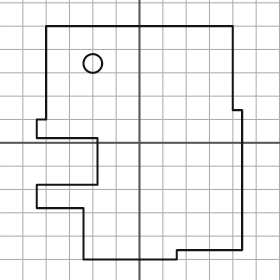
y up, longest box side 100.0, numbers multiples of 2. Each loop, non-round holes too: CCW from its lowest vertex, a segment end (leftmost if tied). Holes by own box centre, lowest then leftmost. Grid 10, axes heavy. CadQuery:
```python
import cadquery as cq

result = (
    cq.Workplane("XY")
    .moveTo(-24.0, -50.0)
    .lineTo(16.0, -50.0)
    .lineTo(16.0, -46.0)
    .lineTo(44.0, -46.0)
    .lineTo(44.0, 14.0)
    .lineTo(40.0, 14.0)
    .lineTo(40.0, 50.0)
    .lineTo(-40.0, 50.0)
    .lineTo(-40.0, 10.0)
    .lineTo(-44.0, 10.0)
    .lineTo(-44.0, 2.0)
    .lineTo(-18.0, 2.0)
    .lineTo(-18.0, -18.0)
    .lineTo(-44.0, -18.0)
    .lineTo(-44.0, -28.0)
    .lineTo(-24.0, -28.0)
    .close()
    .moveTo(-20.0, 34.0)
    .circle(4.0)
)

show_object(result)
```